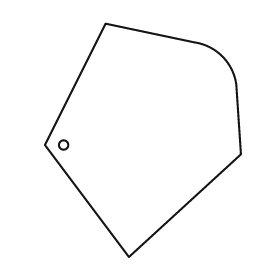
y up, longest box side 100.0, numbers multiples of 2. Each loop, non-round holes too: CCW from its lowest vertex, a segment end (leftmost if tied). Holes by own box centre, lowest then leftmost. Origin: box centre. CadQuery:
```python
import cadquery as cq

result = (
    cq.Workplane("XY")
    .moveTo(-6.0, -50.0)
    .lineTo(42.0, -6.0)
    .lineTo(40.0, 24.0)
    .threePointArc((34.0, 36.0), (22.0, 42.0))
    .lineTo(-16.0, 50.0)
    .lineTo(-42.0, -2.0)
    .close()
    .moveTo(-34.0, -2.0)
    .circle(2.0)
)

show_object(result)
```